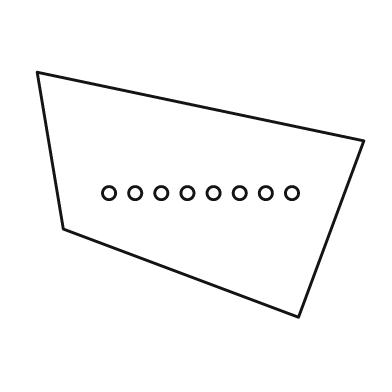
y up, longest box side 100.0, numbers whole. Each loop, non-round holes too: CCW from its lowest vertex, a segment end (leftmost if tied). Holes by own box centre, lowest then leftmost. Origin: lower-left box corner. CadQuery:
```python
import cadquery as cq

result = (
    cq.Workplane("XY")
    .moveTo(80.0, 0.0)
    .lineTo(100.0, 54.0)
    .lineTo(0.0, 75.0)
    .lineTo(8.0, 27.0)
    .close()
    .moveTo(22.0, 38.0)
    .circle(2.0)
    .moveTo(30.0, 38.0)
    .circle(2.0)
    .moveTo(38.0, 38.0)
    .circle(2.0)
    .moveTo(46.0, 38.0)
    .circle(2.0)
    .moveTo(54.0, 38.0)
    .circle(2.0)
    .moveTo(62.0, 38.0)
    .circle(2.0)
    .moveTo(70.0, 38.0)
    .circle(2.0)
    .moveTo(78.0, 38.0)
    .circle(2.0)
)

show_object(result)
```